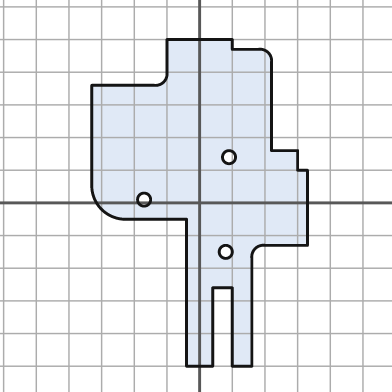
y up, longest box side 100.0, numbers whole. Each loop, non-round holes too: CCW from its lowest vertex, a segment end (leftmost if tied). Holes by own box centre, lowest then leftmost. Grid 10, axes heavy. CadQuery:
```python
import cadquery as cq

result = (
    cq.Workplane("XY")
    .moveTo(-4.0, -50.0)
    .lineTo(4.0, -50.0)
    .lineTo(4.0, -26.0)
    .lineTo(10.0, -26.0)
    .lineTo(10.0, -50.0)
    .lineTo(16.0, -50.0)
    .lineTo(16.0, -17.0)
    .threePointArc((17.0, -14.0), (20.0, -13.0))
    .lineTo(33.0, -13.0)
    .lineTo(33.0, 10.0)
    .lineTo(30.0, 10.0)
    .lineTo(30.0, 16.0)
    .lineTo(22.0, 16.0)
    .lineTo(22.0, 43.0)
    .threePointArc((21.0, 46.0), (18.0, 47.0))
    .lineTo(10.0, 47.0)
    .lineTo(10.0, 50.0)
    .lineTo(-10.0, 50.0)
    .lineTo(-10.0, 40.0)
    .threePointArc((-11.0, 37.0), (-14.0, 36.0))
    .lineTo(-33.0, 36.0)
    .lineTo(-33.0, 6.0)
    .threePointArc((-30.0, -2.0), (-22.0, -5.0))
    .lineTo(-4.0, -5.0)
    .close()
    .moveTo(8.0, -15.0)
    .circle(2.0)
    .moveTo(-17.0, 1.0)
    .circle(2.0)
    .moveTo(9.0, 14.0)
    .circle(2.0)
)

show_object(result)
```